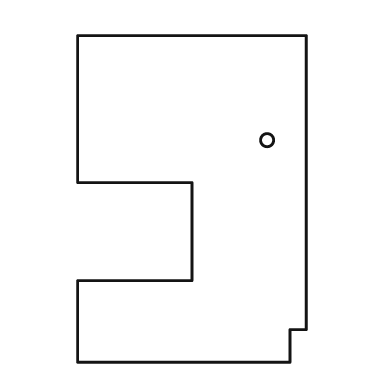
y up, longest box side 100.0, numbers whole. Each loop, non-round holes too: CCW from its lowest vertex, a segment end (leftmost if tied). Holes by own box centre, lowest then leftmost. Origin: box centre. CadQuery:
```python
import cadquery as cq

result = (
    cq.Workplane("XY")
    .moveTo(-35.0, -50.0)
    .lineTo(30.0, -50.0)
    .lineTo(30.0, -40.0)
    .lineTo(35.0, -40.0)
    .lineTo(35.0, 50.0)
    .lineTo(-35.0, 50.0)
    .lineTo(-35.0, 5.0)
    .lineTo(0.0, 5.0)
    .lineTo(0.0, -25.0)
    .lineTo(-35.0, -25.0)
    .close()
    .moveTo(23.0, 18.0)
    .circle(2.0)
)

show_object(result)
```